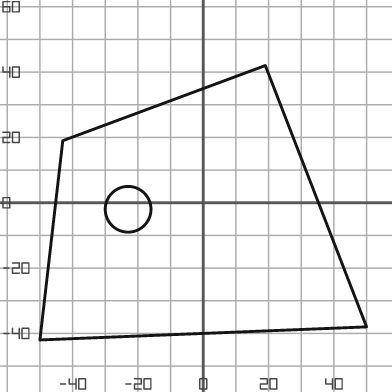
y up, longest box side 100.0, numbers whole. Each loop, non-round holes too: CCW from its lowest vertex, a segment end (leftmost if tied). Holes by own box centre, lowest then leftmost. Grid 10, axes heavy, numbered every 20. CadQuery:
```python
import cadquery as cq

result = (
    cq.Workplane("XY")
    .moveTo(-50.0, -42.0)
    .lineTo(50.0, -38.0)
    .lineTo(19.0, 42.0)
    .lineTo(-43.0, 19.0)
    .close()
    .moveTo(-23.0, -2.0)
    .circle(7.0)
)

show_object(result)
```